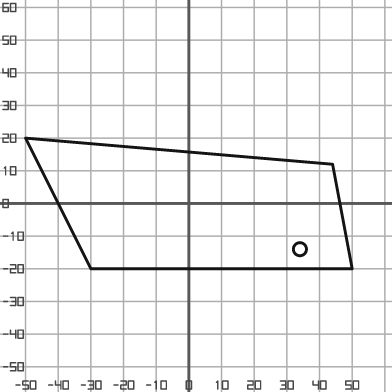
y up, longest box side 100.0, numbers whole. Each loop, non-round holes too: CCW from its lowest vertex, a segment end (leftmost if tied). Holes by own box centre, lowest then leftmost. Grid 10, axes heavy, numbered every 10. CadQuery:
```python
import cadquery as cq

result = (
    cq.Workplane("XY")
    .moveTo(-30.0, -20.0)
    .lineTo(50.0, -20.0)
    .lineTo(44.0, 12.0)
    .lineTo(-50.0, 20.0)
    .close()
    .moveTo(34.0, -14.0)
    .circle(2.0)
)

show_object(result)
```